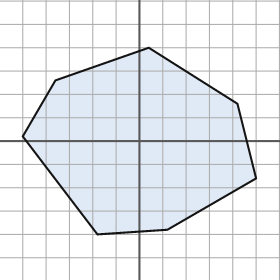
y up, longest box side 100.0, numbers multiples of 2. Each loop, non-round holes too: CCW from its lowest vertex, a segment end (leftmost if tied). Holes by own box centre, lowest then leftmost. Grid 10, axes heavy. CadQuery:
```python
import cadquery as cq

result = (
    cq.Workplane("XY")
    .moveTo(-18.0, -40.0)
    .lineTo(12.0, -38.0)
    .lineTo(50.0, -16.0)
    .lineTo(42.0, 16.0)
    .lineTo(4.0, 40.0)
    .lineTo(-36.0, 26.0)
    .lineTo(-50.0, 2.0)
    .close()
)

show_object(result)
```